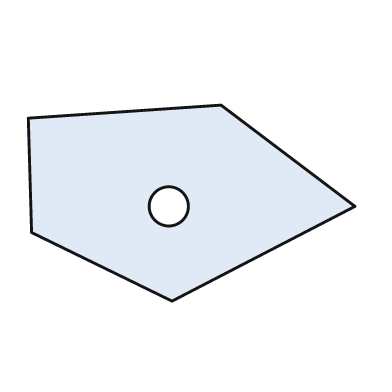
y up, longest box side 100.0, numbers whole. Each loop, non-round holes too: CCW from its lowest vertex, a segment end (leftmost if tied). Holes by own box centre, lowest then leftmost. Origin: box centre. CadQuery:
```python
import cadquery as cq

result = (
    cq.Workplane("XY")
    .moveTo(-6.0, -30.0)
    .lineTo(50.0, -1.0)
    .lineTo(9.0, 30.0)
    .lineTo(-50.0, 26.0)
    .lineTo(-49.0, -9.0)
    .close()
    .moveTo(-7.0, -1.0)
    .circle(6.0)
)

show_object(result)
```